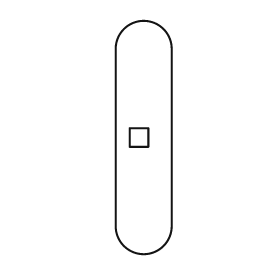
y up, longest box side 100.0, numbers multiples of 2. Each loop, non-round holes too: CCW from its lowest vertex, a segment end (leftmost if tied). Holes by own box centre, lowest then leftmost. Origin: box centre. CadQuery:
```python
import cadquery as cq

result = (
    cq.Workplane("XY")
    .moveTo(-12.0, -38.0)
    .threePointArc((0.0, -50.0), (12.0, -38.0))
    .lineTo(12.0, 38.0)
    .threePointArc((0.0, 50.0), (-12.0, 38.0))
    .close()
    .moveTo(-6.0, -4.0)
    .lineTo(2.0, -4.0)
    .lineTo(2.0, 4.0)
    .lineTo(-6.0, 4.0)
    .close()
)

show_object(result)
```